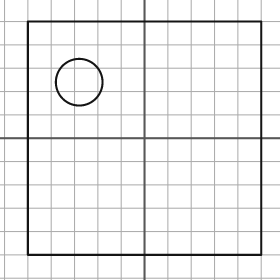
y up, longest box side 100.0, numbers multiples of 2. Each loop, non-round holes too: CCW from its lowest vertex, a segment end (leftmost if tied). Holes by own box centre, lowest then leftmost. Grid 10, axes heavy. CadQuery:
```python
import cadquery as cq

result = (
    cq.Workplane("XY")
    .moveTo(-50.0, -50.0)
    .lineTo(50.0, -50.0)
    .lineTo(50.0, 50.0)
    .lineTo(-50.0, 50.0)
    .close()
    .moveTo(-28.0, 24.0)
    .circle(10.0)
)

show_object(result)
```